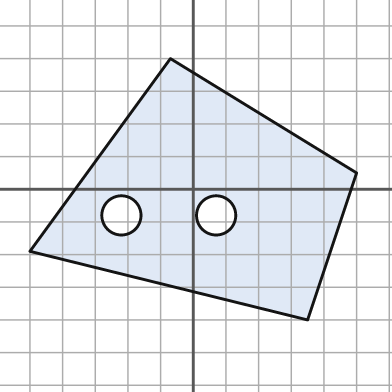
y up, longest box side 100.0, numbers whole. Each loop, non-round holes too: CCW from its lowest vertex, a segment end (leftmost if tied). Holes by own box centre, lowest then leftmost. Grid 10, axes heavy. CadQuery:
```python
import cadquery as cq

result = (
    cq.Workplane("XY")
    .moveTo(35.0, -40.0)
    .lineTo(50.0, 5.0)
    .lineTo(-7.0, 40.0)
    .lineTo(-50.0, -19.0)
    .close()
    .moveTo(-22.0, -8.0)
    .circle(6.0)
    .moveTo(7.0, -8.0)
    .circle(6.0)
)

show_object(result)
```